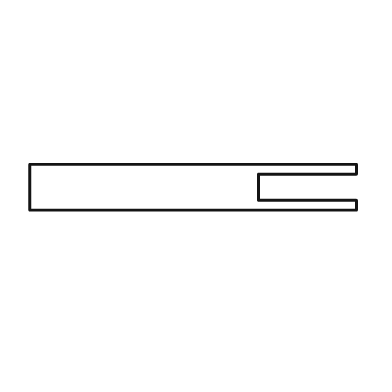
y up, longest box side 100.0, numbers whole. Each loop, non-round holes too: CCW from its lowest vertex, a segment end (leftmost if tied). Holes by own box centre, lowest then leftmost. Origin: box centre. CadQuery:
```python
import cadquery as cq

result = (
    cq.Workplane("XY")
    .moveTo(-50.0, -7.0)
    .lineTo(50.0, -7.0)
    .lineTo(50.0, -4.0)
    .lineTo(20.0, -4.0)
    .lineTo(20.0, 4.0)
    .lineTo(50.0, 4.0)
    .lineTo(50.0, 7.0)
    .lineTo(-50.0, 7.0)
    .close()
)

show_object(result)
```